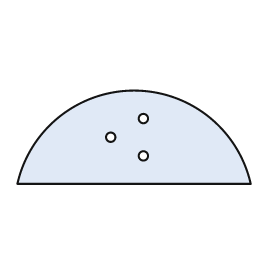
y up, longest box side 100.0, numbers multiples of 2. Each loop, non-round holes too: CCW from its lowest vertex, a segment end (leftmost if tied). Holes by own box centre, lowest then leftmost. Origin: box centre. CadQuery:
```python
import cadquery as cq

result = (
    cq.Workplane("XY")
    .moveTo(-50.0, -20.0)
    .lineTo(50.0, -20.0)
    .threePointArc((0.0, 20.0), (-50.0, -20.0))
    .close()
    .moveTo(4.0, -8.0)
    .circle(2.0)
    .moveTo(-10.0, 0.0)
    .circle(2.0)
    .moveTo(4.0, 8.0)
    .circle(2.0)
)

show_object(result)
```